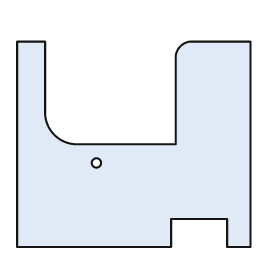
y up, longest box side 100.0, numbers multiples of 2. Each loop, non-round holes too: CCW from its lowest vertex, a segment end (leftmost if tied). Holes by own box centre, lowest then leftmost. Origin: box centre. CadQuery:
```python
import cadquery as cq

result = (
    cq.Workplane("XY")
    .moveTo(-50.0, -44.0)
    .lineTo(16.0, -44.0)
    .lineTo(16.0, -32.0)
    .lineTo(40.0, -32.0)
    .lineTo(40.0, -44.0)
    .lineTo(50.0, -44.0)
    .lineTo(50.0, 44.0)
    .lineTo(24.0, 44.0)
    .threePointArc((20.0, 42.0), (18.0, 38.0))
    .lineTo(18.0, 0.0)
    .lineTo(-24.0, 0.0)
    .threePointArc((-34.0, 4.0), (-38.0, 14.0))
    .lineTo(-38.0, 44.0)
    .lineTo(-50.0, 44.0)
    .close()
    .moveTo(-16.0, -8.0)
    .circle(2.0)
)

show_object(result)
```